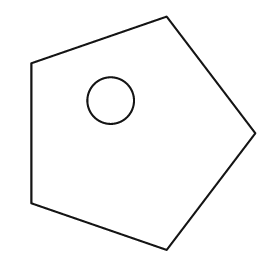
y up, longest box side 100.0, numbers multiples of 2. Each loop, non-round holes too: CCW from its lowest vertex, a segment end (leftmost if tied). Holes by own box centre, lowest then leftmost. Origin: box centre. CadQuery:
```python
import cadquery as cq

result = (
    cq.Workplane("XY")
    .moveTo(10.0, -50.0)
    .lineTo(48.0, 0.0)
    .lineTo(10.0, 50.0)
    .lineTo(-48.0, 30.0)
    .lineTo(-48.0, -30.0)
    .close()
    .moveTo(-14.0, 14.0)
    .circle(10.0)
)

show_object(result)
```